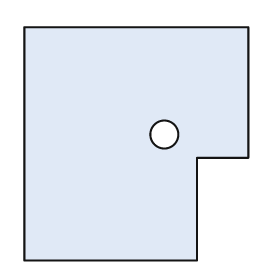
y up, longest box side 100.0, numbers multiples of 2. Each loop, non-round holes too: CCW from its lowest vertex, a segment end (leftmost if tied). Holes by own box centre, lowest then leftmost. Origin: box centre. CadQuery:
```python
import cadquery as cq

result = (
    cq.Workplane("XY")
    .moveTo(-48.0, -50.0)
    .lineTo(26.0, -50.0)
    .lineTo(26.0, -6.0)
    .lineTo(48.0, -6.0)
    .lineTo(48.0, 50.0)
    .lineTo(-48.0, 50.0)
    .close()
    .moveTo(12.0, 4.0)
    .circle(6.0)
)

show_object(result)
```